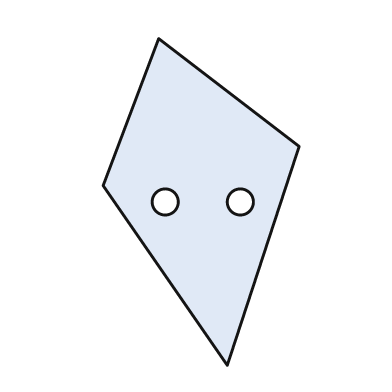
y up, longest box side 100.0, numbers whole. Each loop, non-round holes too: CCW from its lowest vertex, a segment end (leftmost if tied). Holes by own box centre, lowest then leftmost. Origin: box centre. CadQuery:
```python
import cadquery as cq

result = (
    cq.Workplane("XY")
    .moveTo(8.0, -50.0)
    .lineTo(30.0, 17.0)
    .lineTo(-13.0, 50.0)
    .lineTo(-30.0, 5.0)
    .close()
    .moveTo(-11.0, 0.0)
    .circle(4.0)
    .moveTo(12.0, 0.0)
    .circle(4.0)
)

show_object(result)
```